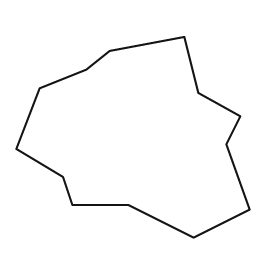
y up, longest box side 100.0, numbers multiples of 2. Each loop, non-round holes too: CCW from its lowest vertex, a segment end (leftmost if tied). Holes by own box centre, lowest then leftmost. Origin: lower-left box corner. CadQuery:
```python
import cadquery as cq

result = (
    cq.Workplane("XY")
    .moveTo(76.0, 0.0)
    .lineTo(100.0, 12.0)
    .lineTo(90.0, 40.0)
    .lineTo(96.0, 52.0)
    .lineTo(78.0, 62.0)
    .lineTo(72.0, 86.0)
    .lineTo(40.0, 80.0)
    .lineTo(30.0, 72.0)
    .lineTo(10.0, 64.0)
    .lineTo(0.0, 38.0)
    .lineTo(20.0, 26.0)
    .lineTo(24.0, 14.0)
    .lineTo(48.0, 14.0)
    .close()
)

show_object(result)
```